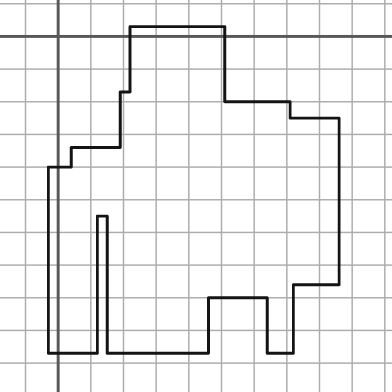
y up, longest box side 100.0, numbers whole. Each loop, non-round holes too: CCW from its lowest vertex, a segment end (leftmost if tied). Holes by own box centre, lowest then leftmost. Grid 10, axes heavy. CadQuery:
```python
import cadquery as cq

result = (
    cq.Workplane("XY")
    .moveTo(-3.0, -97.0)
    .lineTo(12.0, -97.0)
    .lineTo(12.0, -55.0)
    .lineTo(15.0, -55.0)
    .lineTo(15.0, -97.0)
    .lineTo(46.0, -97.0)
    .lineTo(46.0, -80.0)
    .lineTo(64.0, -80.0)
    .lineTo(64.0, -97.0)
    .lineTo(72.0, -97.0)
    .lineTo(72.0, -76.0)
    .lineTo(86.0, -76.0)
    .lineTo(86.0, -25.0)
    .lineTo(71.0, -25.0)
    .lineTo(71.0, -20.0)
    .lineTo(51.0, -20.0)
    .lineTo(51.0, 3.0)
    .lineTo(22.0, 3.0)
    .lineTo(22.0, -17.0)
    .lineTo(19.0, -17.0)
    .lineTo(19.0, -34.0)
    .lineTo(4.0, -34.0)
    .lineTo(4.0, -40.0)
    .lineTo(-3.0, -40.0)
    .close()
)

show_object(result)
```